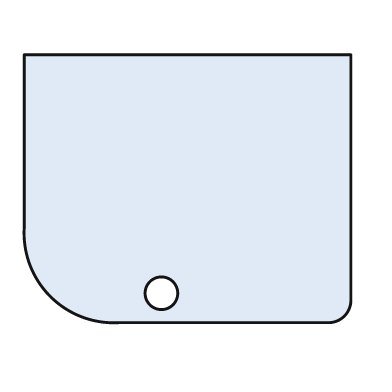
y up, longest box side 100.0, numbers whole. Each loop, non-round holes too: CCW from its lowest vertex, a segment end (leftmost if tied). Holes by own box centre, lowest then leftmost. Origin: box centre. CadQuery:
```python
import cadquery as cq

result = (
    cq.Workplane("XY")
    .moveTo(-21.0, -41.0)
    .lineTo(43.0, -41.0)
    .threePointArc((48.0, -39.0), (50.0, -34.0))
    .lineTo(50.0, 41.0)
    .lineTo(-50.0, 41.0)
    .lineTo(-50.0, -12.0)
    .threePointArc((-42.0, -33.0), (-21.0, -41.0))
    .close()
    .moveTo(-8.0, -32.0)
    .circle(5.0)
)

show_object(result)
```